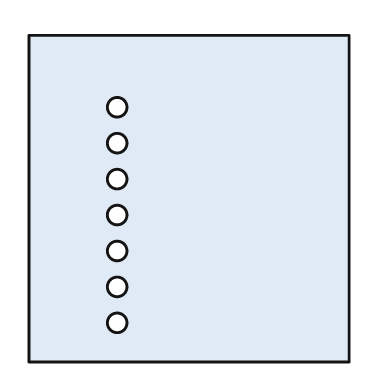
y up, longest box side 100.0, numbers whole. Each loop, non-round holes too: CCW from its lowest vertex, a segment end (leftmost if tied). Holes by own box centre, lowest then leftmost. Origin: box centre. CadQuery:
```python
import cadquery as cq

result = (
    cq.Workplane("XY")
    .moveTo(-49.0, -50.0)
    .lineTo(49.0, -50.0)
    .lineTo(49.0, 50.0)
    .lineTo(-49.0, 50.0)
    .close()
    .moveTo(-22.0, -38.0)
    .circle(3.0)
    .moveTo(-22.0, -27.0)
    .circle(3.0)
    .moveTo(-22.0, -16.0)
    .circle(3.0)
    .moveTo(-22.0, -5.0)
    .circle(3.0)
    .moveTo(-22.0, 6.0)
    .circle(3.0)
    .moveTo(-22.0, 17.0)
    .circle(3.0)
    .moveTo(-22.0, 28.0)
    .circle(3.0)
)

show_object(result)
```